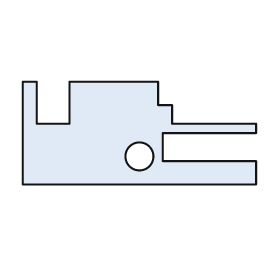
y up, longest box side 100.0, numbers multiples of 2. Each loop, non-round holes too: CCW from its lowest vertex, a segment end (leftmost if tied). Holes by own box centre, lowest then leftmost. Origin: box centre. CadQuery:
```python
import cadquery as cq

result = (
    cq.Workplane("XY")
    .moveTo(-50.0, -22.0)
    .lineTo(50.0, -22.0)
    .lineTo(50.0, -12.0)
    .lineTo(10.0, -12.0)
    .lineTo(10.0, 0.0)
    .lineTo(50.0, 0.0)
    .lineTo(50.0, 4.0)
    .lineTo(14.0, 4.0)
    .lineTo(14.0, 12.0)
    .lineTo(8.0, 12.0)
    .lineTo(8.0, 22.0)
    .lineTo(-30.0, 22.0)
    .lineTo(-30.0, 4.0)
    .lineTo(-44.0, 4.0)
    .lineTo(-44.0, 22.0)
    .lineTo(-50.0, 22.0)
    .close()
    .moveTo(0.0, -10.0)
    .circle(6.0)
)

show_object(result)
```